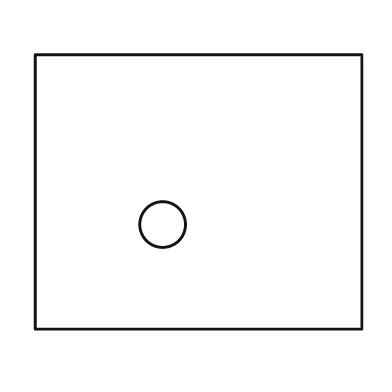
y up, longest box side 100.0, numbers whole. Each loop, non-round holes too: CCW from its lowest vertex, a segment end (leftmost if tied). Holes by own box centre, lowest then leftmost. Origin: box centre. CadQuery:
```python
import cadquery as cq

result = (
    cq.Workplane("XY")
    .moveTo(-50.0, -42.0)
    .lineTo(50.0, -42.0)
    .lineTo(50.0, 42.0)
    .lineTo(-50.0, 42.0)
    .close()
    .moveTo(-11.0, -10.0)
    .circle(7.0)
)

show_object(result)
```